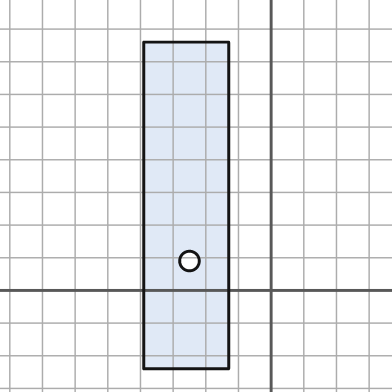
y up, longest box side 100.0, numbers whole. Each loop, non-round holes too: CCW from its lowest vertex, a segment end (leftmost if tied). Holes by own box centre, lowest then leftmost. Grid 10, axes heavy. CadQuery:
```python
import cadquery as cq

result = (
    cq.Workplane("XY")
    .moveTo(-39.0, -24.0)
    .lineTo(-13.0, -24.0)
    .lineTo(-13.0, 76.0)
    .lineTo(-39.0, 76.0)
    .close()
    .moveTo(-25.0, 9.0)
    .circle(3.0)
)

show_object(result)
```